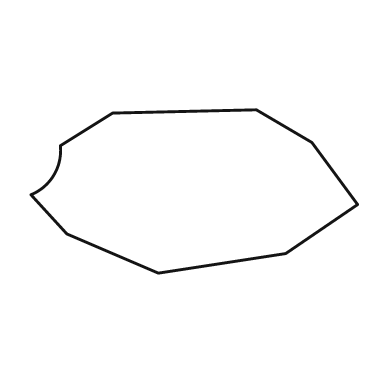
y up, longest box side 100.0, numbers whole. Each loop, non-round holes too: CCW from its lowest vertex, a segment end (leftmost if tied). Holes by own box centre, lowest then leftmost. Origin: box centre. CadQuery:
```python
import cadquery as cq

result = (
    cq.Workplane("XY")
    .moveTo(-11.0, -25.0)
    .lineTo(28.0, -19.0)
    .lineTo(50.0, -4.0)
    .lineTo(36.0, 15.0)
    .lineTo(19.0, 25.0)
    .lineTo(-25.0, 24.0)
    .lineTo(-41.0, 14.0)
    .threePointArc((-43.0, 5.0), (-50.0, -1.0))
    .lineTo(-39.0, -13.0)
    .close()
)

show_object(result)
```